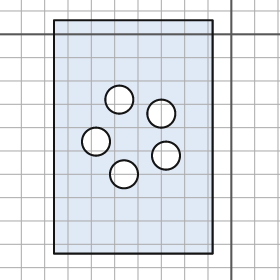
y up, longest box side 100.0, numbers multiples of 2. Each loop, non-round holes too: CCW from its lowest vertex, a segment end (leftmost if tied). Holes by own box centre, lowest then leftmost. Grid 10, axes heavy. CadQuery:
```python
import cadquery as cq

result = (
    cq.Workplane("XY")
    .moveTo(-76.0, -94.0)
    .lineTo(-8.0, -94.0)
    .lineTo(-8.0, 6.0)
    .lineTo(-76.0, 6.0)
    .close()
    .moveTo(-46.0, -60.0)
    .circle(6.0)
    .moveTo(-28.0, -52.0)
    .circle(6.0)
    .moveTo(-58.0, -46.0)
    .circle(6.0)
    .moveTo(-30.0, -34.0)
    .circle(6.0)
    .moveTo(-48.0, -28.0)
    .circle(6.0)
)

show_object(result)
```